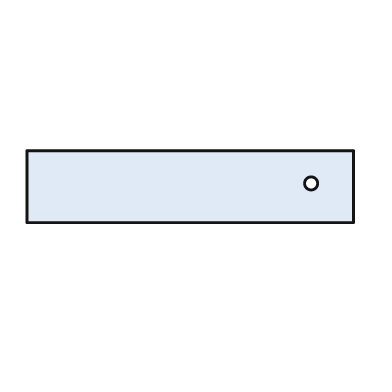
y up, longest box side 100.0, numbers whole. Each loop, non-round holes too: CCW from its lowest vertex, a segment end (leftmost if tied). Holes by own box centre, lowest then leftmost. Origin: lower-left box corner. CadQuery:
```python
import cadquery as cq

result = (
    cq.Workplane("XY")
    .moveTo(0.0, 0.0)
    .lineTo(100.0, 0.0)
    .lineTo(100.0, 22.0)
    .lineTo(0.0, 22.0)
    .close()
    .moveTo(87.0, 12.0)
    .circle(2.0)
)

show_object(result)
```